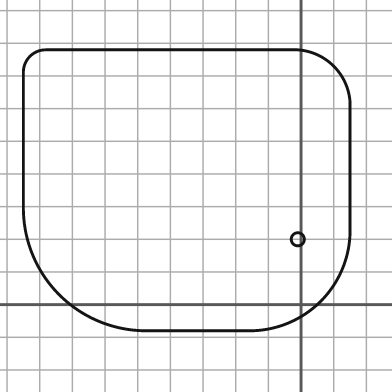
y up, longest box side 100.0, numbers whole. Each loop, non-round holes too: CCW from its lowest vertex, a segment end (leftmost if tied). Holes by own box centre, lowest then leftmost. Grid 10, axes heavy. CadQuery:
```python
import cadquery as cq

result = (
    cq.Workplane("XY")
    .moveTo(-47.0, -8.0)
    .lineTo(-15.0, -8.0)
    .threePointArc((6.0, 1.0), (15.0, 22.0))
    .lineTo(15.0, 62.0)
    .threePointArc((10.0, 73.0), (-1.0, 78.0))
    .lineTo(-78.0, 78.0)
    .threePointArc((-83.0, 76.0), (-85.0, 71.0))
    .lineTo(-85.0, 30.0)
    .threePointArc((-74.0, 3.0), (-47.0, -8.0))
    .close()
    .moveTo(-1.0, 20.0)
    .circle(2.0)
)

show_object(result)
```